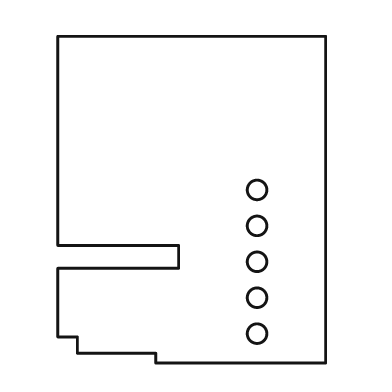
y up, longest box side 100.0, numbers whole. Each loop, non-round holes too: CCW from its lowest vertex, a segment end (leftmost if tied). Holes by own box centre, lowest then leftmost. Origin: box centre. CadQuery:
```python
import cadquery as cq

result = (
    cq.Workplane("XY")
    .moveTo(-11.0, -50.0)
    .lineTo(41.0, -50.0)
    .lineTo(41.0, 50.0)
    .lineTo(-41.0, 50.0)
    .lineTo(-41.0, -14.0)
    .lineTo(-4.0, -14.0)
    .lineTo(-4.0, -21.0)
    .lineTo(-41.0, -21.0)
    .lineTo(-41.0, -42.0)
    .lineTo(-35.0, -42.0)
    .lineTo(-35.0, -47.0)
    .lineTo(-11.0, -47.0)
    .close()
    .moveTo(20.0, -41.0)
    .circle(3.0)
    .moveTo(20.0, -30.0)
    .circle(3.0)
    .moveTo(20.0, -19.0)
    .circle(3.0)
    .moveTo(20.0, -8.0)
    .circle(3.0)
    .moveTo(20.0, 3.0)
    .circle(3.0)
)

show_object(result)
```